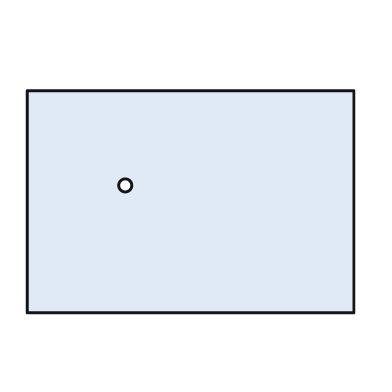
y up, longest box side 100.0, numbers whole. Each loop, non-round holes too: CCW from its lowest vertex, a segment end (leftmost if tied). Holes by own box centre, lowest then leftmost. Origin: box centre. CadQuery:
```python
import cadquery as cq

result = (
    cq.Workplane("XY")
    .moveTo(-50.0, -34.0)
    .lineTo(50.0, -34.0)
    .lineTo(50.0, 34.0)
    .lineTo(-50.0, 34.0)
    .close()
    .moveTo(-20.0, 5.0)
    .circle(2.0)
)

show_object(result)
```